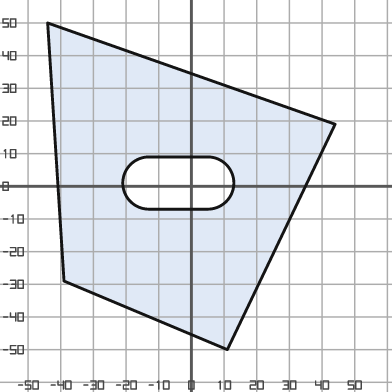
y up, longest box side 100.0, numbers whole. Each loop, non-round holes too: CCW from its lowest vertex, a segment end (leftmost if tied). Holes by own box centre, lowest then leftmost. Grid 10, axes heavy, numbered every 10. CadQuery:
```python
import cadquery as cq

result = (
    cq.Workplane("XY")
    .moveTo(11.0, -50.0)
    .lineTo(44.0, 19.0)
    .lineTo(-44.0, 50.0)
    .lineTo(-39.0, -29.0)
    .close()
    .moveTo(-13.0, -7.0)
    .lineTo(5.0, -7.0)
    .threePointArc((13.0, 1.0), (5.0, 9.0))
    .lineTo(-13.0, 9.0)
    .threePointArc((-21.0, 1.0), (-13.0, -7.0))
    .close()
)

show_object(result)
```